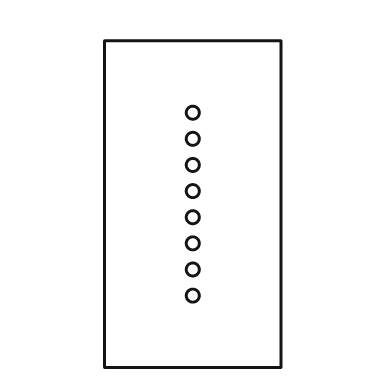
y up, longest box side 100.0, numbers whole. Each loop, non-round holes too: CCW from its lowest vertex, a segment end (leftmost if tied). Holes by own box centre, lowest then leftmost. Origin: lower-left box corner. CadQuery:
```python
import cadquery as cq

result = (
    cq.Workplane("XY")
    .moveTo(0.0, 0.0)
    .lineTo(54.0, 0.0)
    .lineTo(54.0, 100.0)
    .lineTo(0.0, 100.0)
    .close()
    .moveTo(27.0, 22.0)
    .circle(2.0)
    .moveTo(27.0, 30.0)
    .circle(2.0)
    .moveTo(27.0, 38.0)
    .circle(2.0)
    .moveTo(27.0, 46.0)
    .circle(2.0)
    .moveTo(27.0, 54.0)
    .circle(2.0)
    .moveTo(27.0, 62.0)
    .circle(2.0)
    .moveTo(27.0, 70.0)
    .circle(2.0)
    .moveTo(27.0, 78.0)
    .circle(2.0)
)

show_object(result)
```